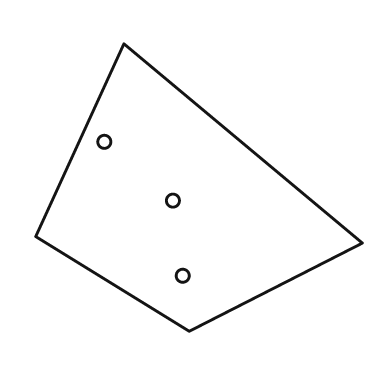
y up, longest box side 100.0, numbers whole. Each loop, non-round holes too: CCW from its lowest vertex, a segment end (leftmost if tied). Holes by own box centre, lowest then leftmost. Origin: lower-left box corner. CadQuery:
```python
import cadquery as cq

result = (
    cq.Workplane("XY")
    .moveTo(47.0, 0.0)
    .lineTo(100.0, 27.0)
    .lineTo(27.0, 88.0)
    .lineTo(0.0, 29.0)
    .close()
    .moveTo(45.0, 17.0)
    .circle(2.0)
    .moveTo(42.0, 40.0)
    .circle(2.0)
    .moveTo(21.0, 58.0)
    .circle(2.0)
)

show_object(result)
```